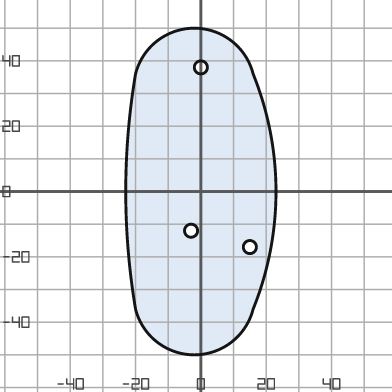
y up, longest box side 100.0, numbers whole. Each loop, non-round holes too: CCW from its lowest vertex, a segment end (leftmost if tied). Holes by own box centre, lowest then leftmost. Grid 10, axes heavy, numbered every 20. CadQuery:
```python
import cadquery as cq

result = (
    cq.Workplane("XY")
    .moveTo(-20.0, -36.0)
    .threePointArc((-2.0, -50.0), (16.0, -36.0))
    .threePointArc((23.0, 0.0), (16.0, 36.0))
    .threePointArc((-2.0, 50.0), (-20.0, 36.0))
    .threePointArc((-23.0, 0.0), (-20.0, -36.0))
    .close()
    .moveTo(15.0, -17.0)
    .circle(2.0)
    .moveTo(-3.0, -12.0)
    .circle(2.0)
    .moveTo(0.0, 38.0)
    .circle(2.0)
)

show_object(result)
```